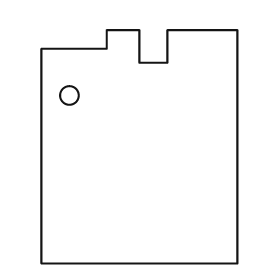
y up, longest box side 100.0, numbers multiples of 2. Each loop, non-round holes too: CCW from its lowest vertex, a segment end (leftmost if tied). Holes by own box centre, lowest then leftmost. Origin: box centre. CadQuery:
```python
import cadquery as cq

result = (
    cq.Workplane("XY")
    .moveTo(-42.0, -50.0)
    .lineTo(42.0, -50.0)
    .lineTo(42.0, 50.0)
    .lineTo(12.0, 50.0)
    .lineTo(12.0, 36.0)
    .lineTo(0.0, 36.0)
    .lineTo(0.0, 50.0)
    .lineTo(-14.0, 50.0)
    .lineTo(-14.0, 42.0)
    .lineTo(-42.0, 42.0)
    .close()
    .moveTo(-30.0, 22.0)
    .circle(4.0)
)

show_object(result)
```